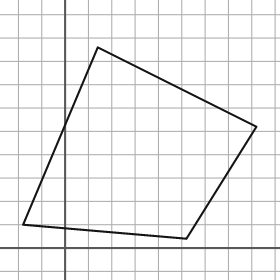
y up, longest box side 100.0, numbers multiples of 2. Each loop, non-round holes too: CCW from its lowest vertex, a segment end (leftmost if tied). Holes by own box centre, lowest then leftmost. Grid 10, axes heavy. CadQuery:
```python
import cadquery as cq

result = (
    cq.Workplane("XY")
    .moveTo(52.0, 4.0)
    .lineTo(82.0, 52.0)
    .lineTo(14.0, 86.0)
    .lineTo(-18.0, 10.0)
    .close()
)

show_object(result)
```